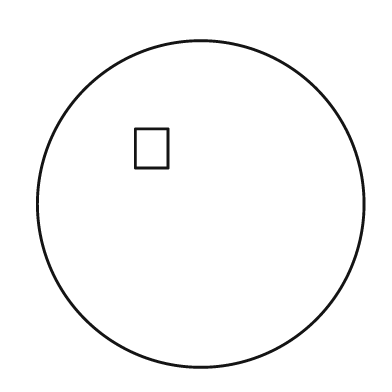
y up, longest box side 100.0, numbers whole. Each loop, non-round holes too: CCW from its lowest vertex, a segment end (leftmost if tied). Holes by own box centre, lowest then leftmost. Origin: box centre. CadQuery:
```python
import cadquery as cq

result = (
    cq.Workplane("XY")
    .moveTo(0.0, 0.0)
    .circle(50.0)
    .moveTo(-20.0, 11.0)
    .lineTo(-10.0, 11.0)
    .lineTo(-10.0, 23.0)
    .lineTo(-20.0, 23.0)
    .close()
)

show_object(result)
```